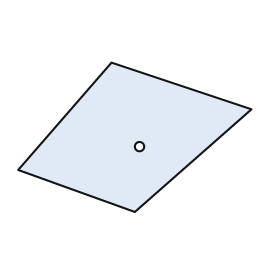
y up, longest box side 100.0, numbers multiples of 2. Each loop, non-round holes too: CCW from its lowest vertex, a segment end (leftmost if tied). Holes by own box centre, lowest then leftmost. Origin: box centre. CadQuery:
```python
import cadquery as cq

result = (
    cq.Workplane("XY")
    .moveTo(0.0, -32.0)
    .lineTo(50.0, 12.0)
    .lineTo(-10.0, 32.0)
    .lineTo(-50.0, -14.0)
    .close()
    .moveTo(2.0, -4.0)
    .circle(2.0)
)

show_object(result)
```